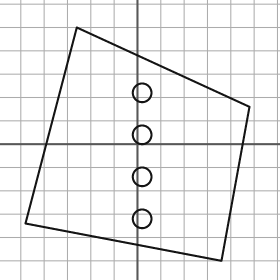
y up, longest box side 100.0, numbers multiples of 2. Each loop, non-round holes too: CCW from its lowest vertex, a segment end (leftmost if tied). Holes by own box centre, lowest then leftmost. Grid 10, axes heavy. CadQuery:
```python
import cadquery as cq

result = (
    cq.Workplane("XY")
    .moveTo(36.0, -50.0)
    .lineTo(48.0, 16.0)
    .lineTo(-26.0, 50.0)
    .lineTo(-48.0, -34.0)
    .close()
    .moveTo(2.0, -32.0)
    .circle(4.0)
    .moveTo(2.0, -14.0)
    .circle(4.0)
    .moveTo(2.0, 4.0)
    .circle(4.0)
    .moveTo(2.0, 22.0)
    .circle(4.0)
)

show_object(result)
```